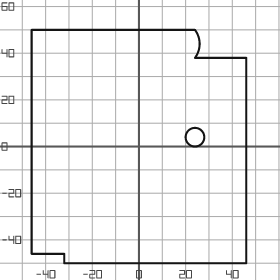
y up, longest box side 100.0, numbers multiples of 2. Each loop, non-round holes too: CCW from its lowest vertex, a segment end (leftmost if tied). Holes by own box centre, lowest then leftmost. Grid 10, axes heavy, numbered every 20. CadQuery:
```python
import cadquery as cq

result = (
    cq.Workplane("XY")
    .moveTo(-32.0, -50.0)
    .lineTo(46.0, -50.0)
    .lineTo(46.0, 38.0)
    .lineTo(24.0, 38.0)
    .threePointArc((26.0, 44.0), (24.0, 50.0))
    .lineTo(-46.0, 50.0)
    .lineTo(-46.0, -46.0)
    .lineTo(-32.0, -46.0)
    .close()
    .moveTo(24.0, 4.0)
    .circle(4.0)
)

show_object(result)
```